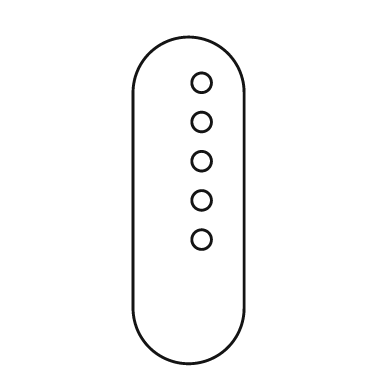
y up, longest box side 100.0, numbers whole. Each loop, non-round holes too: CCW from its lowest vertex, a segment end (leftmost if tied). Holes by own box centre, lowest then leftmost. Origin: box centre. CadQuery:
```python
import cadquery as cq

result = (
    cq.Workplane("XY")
    .moveTo(-17.0, -33.0)
    .threePointArc((0.0, -50.0), (17.0, -33.0))
    .lineTo(17.0, 33.0)
    .threePointArc((0.0, 50.0), (-17.0, 33.0))
    .close()
    .moveTo(4.0, -12.0)
    .circle(3.0)
    .moveTo(4.0, 0.0)
    .circle(3.0)
    .moveTo(4.0, 12.0)
    .circle(3.0)
    .moveTo(4.0, 24.0)
    .circle(3.0)
    .moveTo(4.0, 36.0)
    .circle(3.0)
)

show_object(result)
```